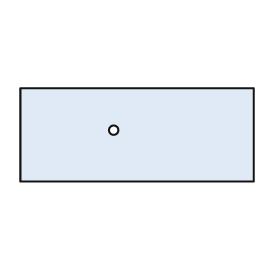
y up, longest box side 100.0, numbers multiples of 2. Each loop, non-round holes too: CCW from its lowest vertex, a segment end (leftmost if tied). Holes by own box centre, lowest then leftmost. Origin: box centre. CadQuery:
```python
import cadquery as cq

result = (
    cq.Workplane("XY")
    .moveTo(-50.0, -20.0)
    .lineTo(50.0, -20.0)
    .lineTo(50.0, 20.0)
    .lineTo(-50.0, 20.0)
    .close()
    .moveTo(-10.0, 2.0)
    .circle(2.0)
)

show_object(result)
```